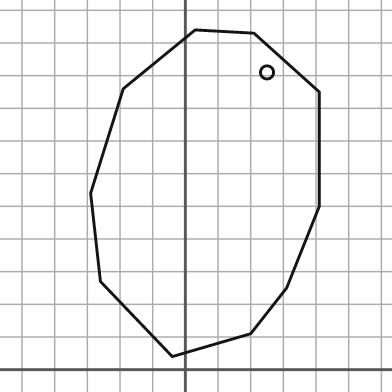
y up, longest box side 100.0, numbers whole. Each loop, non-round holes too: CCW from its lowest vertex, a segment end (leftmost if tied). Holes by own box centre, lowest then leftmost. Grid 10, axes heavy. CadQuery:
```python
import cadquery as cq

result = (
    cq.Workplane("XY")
    .moveTo(-4.0, 4.0)
    .lineTo(20.0, 11.0)
    .lineTo(31.0, 25.0)
    .lineTo(41.0, 50.0)
    .lineTo(41.0, 85.0)
    .lineTo(21.0, 103.0)
    .lineTo(3.0, 104.0)
    .lineTo(-19.0, 86.0)
    .lineTo(-29.0, 54.0)
    .lineTo(-26.0, 27.0)
    .close()
    .moveTo(25.0, 91.0)
    .circle(2.0)
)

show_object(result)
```